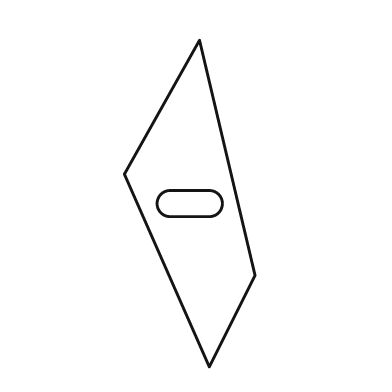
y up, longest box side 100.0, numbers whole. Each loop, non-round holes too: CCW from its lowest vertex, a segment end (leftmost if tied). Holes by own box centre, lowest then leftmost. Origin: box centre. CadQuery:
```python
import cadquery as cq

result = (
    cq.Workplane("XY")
    .moveTo(6.0, -50.0)
    .lineTo(20.0, -22.0)
    .lineTo(3.0, 50.0)
    .lineTo(-20.0, 9.0)
    .close()
    .moveTo(-6.0, -4.0)
    .lineTo(6.0, -4.0)
    .threePointArc((10.0, 0.0), (6.0, 4.0))
    .lineTo(-6.0, 4.0)
    .threePointArc((-10.0, 0.0), (-6.0, -4.0))
    .close()
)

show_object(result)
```